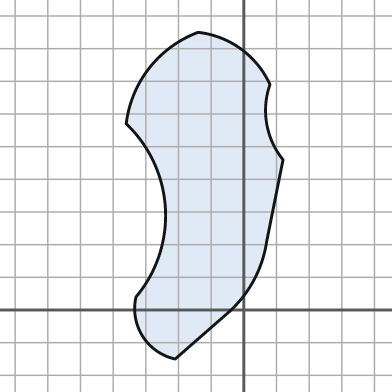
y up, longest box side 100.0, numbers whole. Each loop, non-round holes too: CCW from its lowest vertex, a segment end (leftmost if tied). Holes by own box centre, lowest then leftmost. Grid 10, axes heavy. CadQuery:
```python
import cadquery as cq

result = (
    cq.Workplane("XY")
    .moveTo(-21.0, -15.0)
    .lineTo(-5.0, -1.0)
    .threePointArc((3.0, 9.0), (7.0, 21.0))
    .lineTo(12.0, 46.0)
    .threePointArc((7.0, 57.0), (8.0, 69.0))
    .threePointArc((-1.0, 80.0), (-14.0, 85.0))
    .threePointArc((-29.0, 74.0), (-36.0, 57.0))
    .threePointArc((-24.0, 31.0), (-33.0, 4.0))
    .threePointArc((-31.0, -8.0), (-21.0, -15.0))
    .close()
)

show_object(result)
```